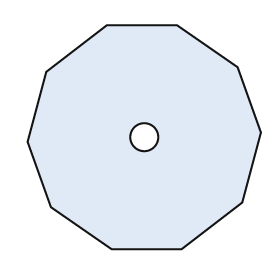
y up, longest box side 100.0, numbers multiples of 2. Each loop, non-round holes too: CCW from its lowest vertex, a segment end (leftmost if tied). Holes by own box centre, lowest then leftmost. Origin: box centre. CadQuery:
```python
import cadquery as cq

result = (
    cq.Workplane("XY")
    .moveTo(-14.0, -48.0)
    .lineTo(16.0, -48.0)
    .lineTo(42.0, -28.0)
    .lineTo(50.0, 2.0)
    .lineTo(40.0, 30.0)
    .lineTo(14.0, 48.0)
    .lineTo(-16.0, 48.0)
    .lineTo(-42.0, 28.0)
    .lineTo(-50.0, -2.0)
    .lineTo(-40.0, -30.0)
    .close()
    .moveTo(0.0, 0.0)
    .circle(6.0)
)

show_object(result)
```